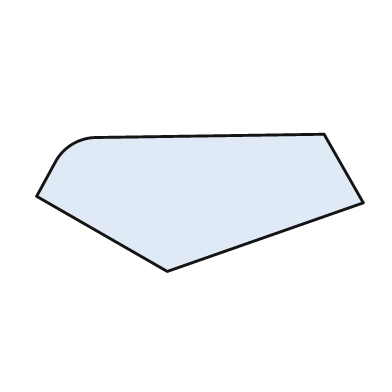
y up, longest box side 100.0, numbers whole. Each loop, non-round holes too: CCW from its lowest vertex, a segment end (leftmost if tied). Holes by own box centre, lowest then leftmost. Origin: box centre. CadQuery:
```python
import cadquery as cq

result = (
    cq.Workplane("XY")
    .moveTo(-10.0, -21.0)
    .lineTo(50.0, 0.0)
    .lineTo(38.0, 21.0)
    .lineTo(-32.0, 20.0)
    .threePointArc((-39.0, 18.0), (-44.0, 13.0))
    .lineTo(-50.0, 2.0)
    .close()
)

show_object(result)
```